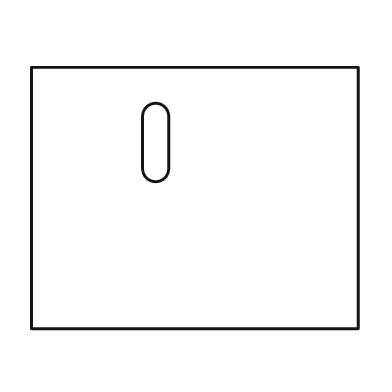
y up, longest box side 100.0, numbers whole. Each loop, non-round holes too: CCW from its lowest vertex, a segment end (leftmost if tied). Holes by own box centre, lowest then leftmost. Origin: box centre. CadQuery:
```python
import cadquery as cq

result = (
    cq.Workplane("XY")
    .moveTo(-50.0, -40.0)
    .lineTo(50.0, -40.0)
    .lineTo(50.0, 40.0)
    .lineTo(-50.0, 40.0)
    .close()
    .moveTo(-16.0, 9.0)
    .threePointArc((-12.0, 5.0), (-8.0, 9.0))
    .lineTo(-8.0, 25.0)
    .threePointArc((-12.0, 29.0), (-16.0, 25.0))
    .close()
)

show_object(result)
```